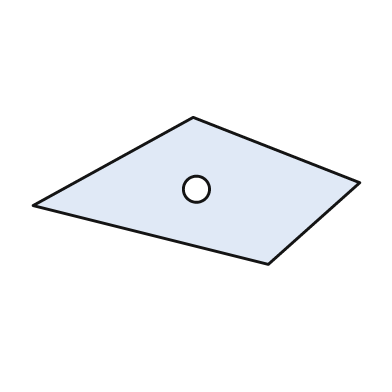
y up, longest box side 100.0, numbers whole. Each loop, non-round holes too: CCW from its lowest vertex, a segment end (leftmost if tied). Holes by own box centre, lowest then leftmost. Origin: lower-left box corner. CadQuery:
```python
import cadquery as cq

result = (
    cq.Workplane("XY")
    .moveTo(72.0, 0.0)
    .lineTo(100.0, 25.0)
    .lineTo(49.0, 45.0)
    .lineTo(0.0, 18.0)
    .close()
    .moveTo(50.0, 23.0)
    .circle(4.0)
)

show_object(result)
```